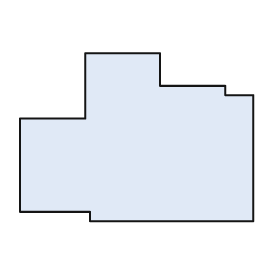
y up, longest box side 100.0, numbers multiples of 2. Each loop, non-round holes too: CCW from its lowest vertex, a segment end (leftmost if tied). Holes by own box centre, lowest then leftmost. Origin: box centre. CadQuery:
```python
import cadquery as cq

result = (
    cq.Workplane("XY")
    .moveTo(-20.0, -36.0)
    .lineTo(50.0, -36.0)
    .lineTo(50.0, 18.0)
    .lineTo(38.0, 18.0)
    .lineTo(38.0, 22.0)
    .lineTo(10.0, 22.0)
    .lineTo(10.0, 36.0)
    .lineTo(-22.0, 36.0)
    .lineTo(-22.0, 8.0)
    .lineTo(-50.0, 8.0)
    .lineTo(-50.0, -32.0)
    .lineTo(-20.0, -32.0)
    .close()
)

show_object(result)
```